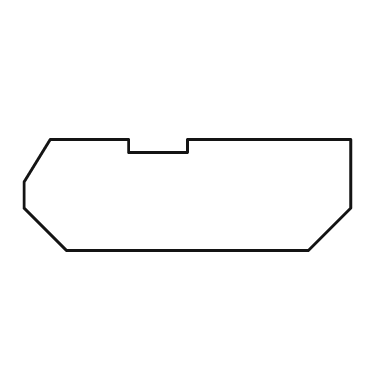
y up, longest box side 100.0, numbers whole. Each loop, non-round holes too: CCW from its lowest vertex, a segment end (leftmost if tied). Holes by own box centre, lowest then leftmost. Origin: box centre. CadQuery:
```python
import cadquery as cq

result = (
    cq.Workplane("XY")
    .moveTo(-37.0, -17.0)
    .lineTo(37.0, -17.0)
    .lineTo(50.0, -4.0)
    .lineTo(50.0, 17.0)
    .lineTo(0.0, 17.0)
    .lineTo(0.0, 13.0)
    .lineTo(-18.0, 13.0)
    .lineTo(-18.0, 17.0)
    .lineTo(-42.0, 17.0)
    .lineTo(-50.0, 4.0)
    .lineTo(-50.0, -4.0)
    .close()
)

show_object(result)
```